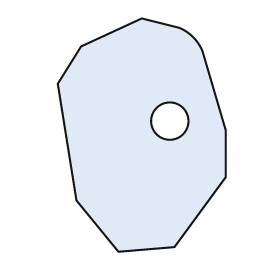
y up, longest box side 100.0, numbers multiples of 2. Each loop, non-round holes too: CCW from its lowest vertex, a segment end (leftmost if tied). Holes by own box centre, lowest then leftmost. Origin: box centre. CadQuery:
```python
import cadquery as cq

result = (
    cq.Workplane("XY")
    .moveTo(-10.0, -50.0)
    .lineTo(14.0, -48.0)
    .lineTo(36.0, -18.0)
    .lineTo(36.0, 2.0)
    .lineTo(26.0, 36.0)
    .threePointArc((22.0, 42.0), (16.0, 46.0))
    .lineTo(0.0, 50.0)
    .lineTo(-26.0, 38.0)
    .lineTo(-36.0, 22.0)
    .lineTo(-28.0, -28.0)
    .close()
    .moveTo(12.0, 6.0)
    .circle(8.0)
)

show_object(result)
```